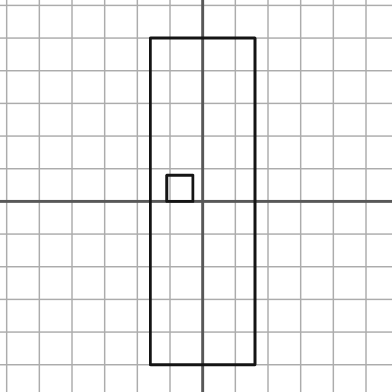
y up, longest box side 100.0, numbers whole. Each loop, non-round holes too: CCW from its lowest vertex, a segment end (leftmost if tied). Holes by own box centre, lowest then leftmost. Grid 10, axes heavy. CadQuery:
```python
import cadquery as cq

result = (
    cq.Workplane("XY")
    .moveTo(-16.0, -50.0)
    .lineTo(16.0, -50.0)
    .lineTo(16.0, 50.0)
    .lineTo(-16.0, 50.0)
    .close()
    .moveTo(-11.0, 0.0)
    .lineTo(-3.0, 0.0)
    .lineTo(-3.0, 8.0)
    .lineTo(-11.0, 8.0)
    .close()
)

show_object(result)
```